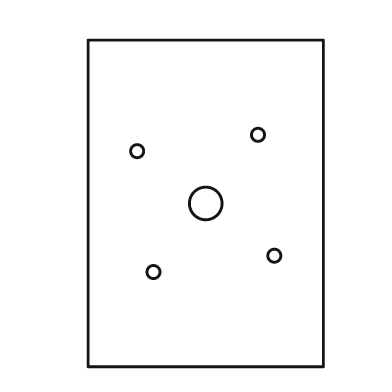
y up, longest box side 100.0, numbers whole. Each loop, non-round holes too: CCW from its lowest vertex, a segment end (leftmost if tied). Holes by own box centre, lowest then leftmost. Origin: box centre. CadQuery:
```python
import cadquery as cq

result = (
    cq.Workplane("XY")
    .moveTo(-36.0, -50.0)
    .lineTo(36.0, -50.0)
    .lineTo(36.0, 50.0)
    .lineTo(-36.0, 50.0)
    .close()
    .moveTo(-16.0, -21.0)
    .circle(2.0)
    .moveTo(21.0, -16.0)
    .circle(2.0)
    .moveTo(0.0, 0.0)
    .circle(5.0)
    .moveTo(-21.0, 16.0)
    .circle(2.0)
    .moveTo(16.0, 21.0)
    .circle(2.0)
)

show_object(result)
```